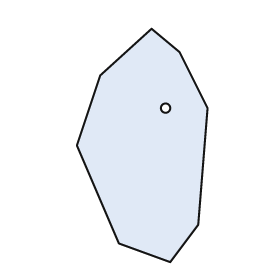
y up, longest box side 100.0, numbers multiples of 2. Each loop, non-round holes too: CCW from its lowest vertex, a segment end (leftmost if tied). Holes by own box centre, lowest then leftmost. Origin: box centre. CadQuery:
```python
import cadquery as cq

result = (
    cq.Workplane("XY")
    .moveTo(12.0, -50.0)
    .lineTo(24.0, -34.0)
    .lineTo(28.0, 16.0)
    .lineTo(16.0, 40.0)
    .lineTo(4.0, 50.0)
    .lineTo(-18.0, 30.0)
    .lineTo(-28.0, 0.0)
    .lineTo(-10.0, -42.0)
    .close()
    .moveTo(10.0, 16.0)
    .circle(2.0)
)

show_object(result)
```